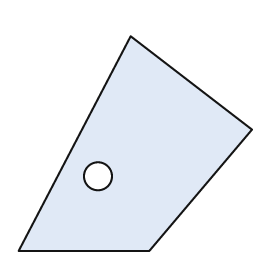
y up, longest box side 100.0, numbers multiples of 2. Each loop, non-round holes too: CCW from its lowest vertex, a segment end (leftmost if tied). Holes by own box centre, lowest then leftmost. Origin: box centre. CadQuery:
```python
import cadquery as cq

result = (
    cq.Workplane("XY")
    .moveTo(-50.0, -46.0)
    .lineTo(6.0, -46.0)
    .lineTo(50.0, 6.0)
    .lineTo(-2.0, 46.0)
    .close()
    .moveTo(-16.0, -14.0)
    .circle(6.0)
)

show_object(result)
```